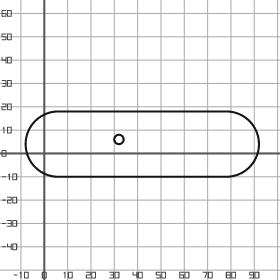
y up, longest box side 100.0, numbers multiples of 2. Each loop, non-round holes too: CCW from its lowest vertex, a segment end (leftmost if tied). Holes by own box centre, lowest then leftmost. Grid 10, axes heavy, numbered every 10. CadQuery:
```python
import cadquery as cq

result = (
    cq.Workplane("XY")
    .moveTo(6.0, -10.0)
    .lineTo(78.0, -10.0)
    .threePointArc((92.0, 4.0), (78.0, 18.0))
    .lineTo(6.0, 18.0)
    .threePointArc((-8.0, 4.0), (6.0, -10.0))
    .close()
    .moveTo(32.0, 6.0)
    .circle(2.0)
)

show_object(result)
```